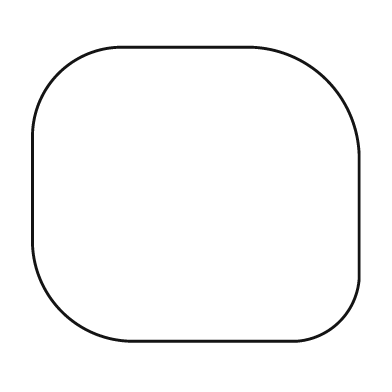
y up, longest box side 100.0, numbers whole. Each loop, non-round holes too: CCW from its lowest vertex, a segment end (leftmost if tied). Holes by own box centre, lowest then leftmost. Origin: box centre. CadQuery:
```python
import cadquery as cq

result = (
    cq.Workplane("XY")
    .moveTo(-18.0, -45.0)
    .lineTo(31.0, -45.0)
    .threePointArc((44.0, -39.0), (50.0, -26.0))
    .lineTo(50.0, 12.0)
    .threePointArc((40.0, 35.0), (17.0, 45.0))
    .lineTo(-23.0, 45.0)
    .threePointArc((-42.0, 37.0), (-50.0, 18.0))
    .lineTo(-50.0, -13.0)
    .threePointArc((-41.0, -36.0), (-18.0, -45.0))
    .close()
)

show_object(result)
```